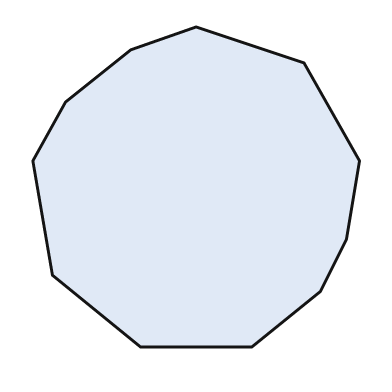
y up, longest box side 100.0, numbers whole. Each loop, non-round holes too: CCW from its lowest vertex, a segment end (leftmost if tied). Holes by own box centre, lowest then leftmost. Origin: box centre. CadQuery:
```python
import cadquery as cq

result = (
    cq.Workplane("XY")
    .moveTo(-17.0, -49.0)
    .lineTo(17.0, -49.0)
    .lineTo(38.0, -32.0)
    .lineTo(46.0, -16.0)
    .lineTo(50.0, 8.0)
    .lineTo(33.0, 38.0)
    .lineTo(0.0, 49.0)
    .lineTo(-20.0, 42.0)
    .lineTo(-40.0, 26.0)
    .lineTo(-50.0, 8.0)
    .lineTo(-44.0, -27.0)
    .close()
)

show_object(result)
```